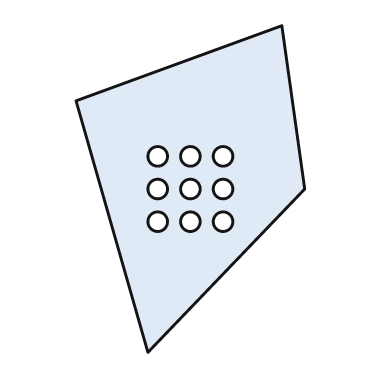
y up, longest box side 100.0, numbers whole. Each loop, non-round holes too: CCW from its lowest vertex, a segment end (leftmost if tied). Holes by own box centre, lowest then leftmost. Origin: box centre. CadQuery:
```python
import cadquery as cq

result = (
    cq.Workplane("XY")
    .moveTo(-13.0, -50.0)
    .lineTo(35.0, 0.0)
    .lineTo(28.0, 50.0)
    .lineTo(-35.0, 27.0)
    .close()
    .moveTo(-10.0, -10.0)
    .circle(3.0)
    .moveTo(0.0, -10.0)
    .circle(3.0)
    .moveTo(10.0, -10.0)
    .circle(3.0)
    .moveTo(-10.0, 0.0)
    .circle(3.0)
    .moveTo(0.0, 0.0)
    .circle(3.0)
    .moveTo(10.0, 0.0)
    .circle(3.0)
    .moveTo(-10.0, 10.0)
    .circle(3.0)
    .moveTo(0.0, 10.0)
    .circle(3.0)
    .moveTo(10.0, 10.0)
    .circle(3.0)
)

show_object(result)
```